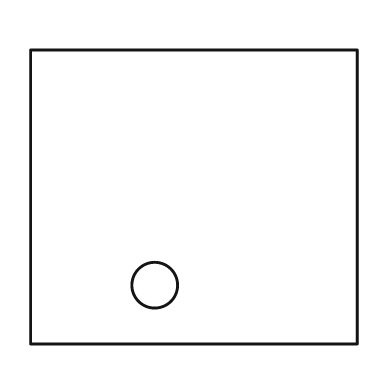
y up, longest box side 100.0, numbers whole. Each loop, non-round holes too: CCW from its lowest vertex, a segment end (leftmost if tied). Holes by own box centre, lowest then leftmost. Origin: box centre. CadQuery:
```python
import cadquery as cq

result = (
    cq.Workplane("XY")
    .moveTo(-50.0, -45.0)
    .lineTo(50.0, -45.0)
    .lineTo(50.0, 45.0)
    .lineTo(-50.0, 45.0)
    .close()
    .moveTo(-12.0, -27.0)
    .circle(7.0)
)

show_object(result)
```